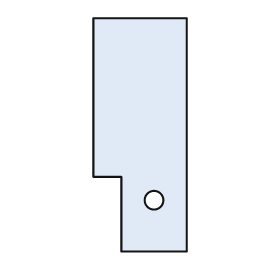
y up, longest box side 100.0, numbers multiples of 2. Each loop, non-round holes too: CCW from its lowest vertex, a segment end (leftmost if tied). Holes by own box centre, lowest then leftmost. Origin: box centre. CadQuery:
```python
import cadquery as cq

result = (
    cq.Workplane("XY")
    .moveTo(-8.0, -50.0)
    .lineTo(20.0, -50.0)
    .lineTo(20.0, 50.0)
    .lineTo(-20.0, 50.0)
    .lineTo(-20.0, -18.0)
    .lineTo(-8.0, -18.0)
    .close()
    .moveTo(6.0, -28.0)
    .circle(4.0)
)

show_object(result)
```